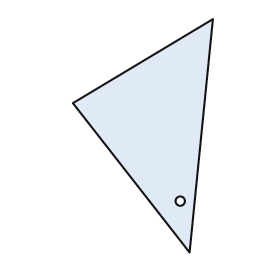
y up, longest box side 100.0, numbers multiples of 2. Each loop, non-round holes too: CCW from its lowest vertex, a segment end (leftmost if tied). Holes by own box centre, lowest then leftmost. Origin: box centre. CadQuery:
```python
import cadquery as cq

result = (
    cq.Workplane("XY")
    .moveTo(20.0, -50.0)
    .lineTo(30.0, 50.0)
    .lineTo(-30.0, 14.0)
    .close()
    .moveTo(16.0, -28.0)
    .circle(2.0)
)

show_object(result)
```